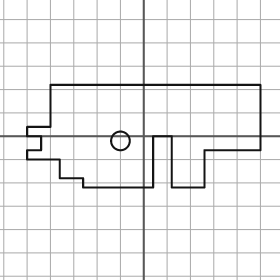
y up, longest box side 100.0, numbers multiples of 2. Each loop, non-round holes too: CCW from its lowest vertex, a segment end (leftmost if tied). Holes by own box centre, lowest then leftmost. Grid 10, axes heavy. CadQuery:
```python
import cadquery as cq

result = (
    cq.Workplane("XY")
    .moveTo(-26.0, -22.0)
    .lineTo(4.0, -22.0)
    .lineTo(4.0, 0.0)
    .lineTo(12.0, 0.0)
    .lineTo(12.0, -22.0)
    .lineTo(26.0, -22.0)
    .lineTo(26.0, -6.0)
    .lineTo(50.0, -6.0)
    .lineTo(50.0, 22.0)
    .lineTo(-40.0, 22.0)
    .lineTo(-40.0, 4.0)
    .lineTo(-50.0, 4.0)
    .lineTo(-50.0, 0.0)
    .lineTo(-44.0, 0.0)
    .lineTo(-44.0, -6.0)
    .lineTo(-50.0, -6.0)
    .lineTo(-50.0, -10.0)
    .lineTo(-36.0, -10.0)
    .lineTo(-36.0, -18.0)
    .lineTo(-26.0, -18.0)
    .close()
    .moveTo(-10.0, -2.0)
    .circle(4.0)
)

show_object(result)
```